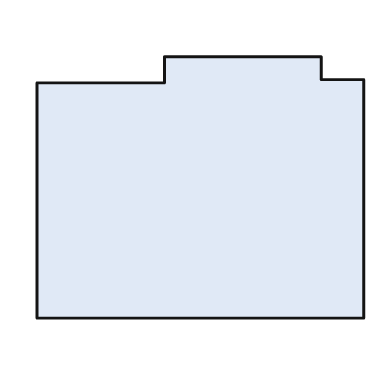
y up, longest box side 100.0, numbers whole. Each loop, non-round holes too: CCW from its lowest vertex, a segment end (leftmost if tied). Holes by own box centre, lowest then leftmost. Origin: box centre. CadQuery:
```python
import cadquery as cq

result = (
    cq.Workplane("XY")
    .moveTo(-50.0, -40.0)
    .lineTo(50.0, -40.0)
    .lineTo(50.0, 33.0)
    .lineTo(37.0, 33.0)
    .lineTo(37.0, 40.0)
    .lineTo(-11.0, 40.0)
    .lineTo(-11.0, 32.0)
    .lineTo(-50.0, 32.0)
    .close()
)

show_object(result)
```